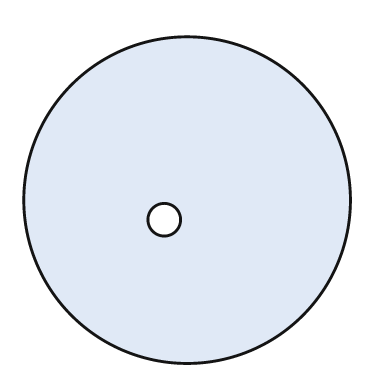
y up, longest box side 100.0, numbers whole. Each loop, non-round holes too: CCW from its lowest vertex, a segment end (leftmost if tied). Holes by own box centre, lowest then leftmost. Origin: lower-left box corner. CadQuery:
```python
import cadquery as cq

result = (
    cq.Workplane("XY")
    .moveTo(50.0, 50.0)
    .circle(50.0)
    .moveTo(43.0, 44.0)
    .circle(5.0)
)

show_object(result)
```